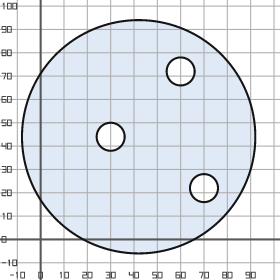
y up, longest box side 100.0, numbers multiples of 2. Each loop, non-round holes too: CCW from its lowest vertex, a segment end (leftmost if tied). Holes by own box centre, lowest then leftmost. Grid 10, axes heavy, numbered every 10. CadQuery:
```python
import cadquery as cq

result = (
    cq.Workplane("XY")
    .moveTo(42.0, 44.0)
    .circle(50.0)
    .moveTo(70.0, 22.0)
    .circle(6.0)
    .moveTo(30.0, 44.0)
    .circle(6.0)
    .moveTo(60.0, 72.0)
    .circle(6.0)
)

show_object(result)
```